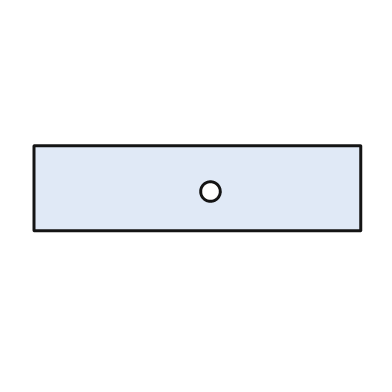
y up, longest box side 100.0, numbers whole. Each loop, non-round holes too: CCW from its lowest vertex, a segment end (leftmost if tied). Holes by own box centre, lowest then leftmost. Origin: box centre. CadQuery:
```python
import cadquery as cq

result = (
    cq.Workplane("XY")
    .moveTo(-50.0, -13.0)
    .lineTo(50.0, -13.0)
    .lineTo(50.0, 13.0)
    .lineTo(-50.0, 13.0)
    .close()
    .moveTo(4.0, -1.0)
    .circle(3.0)
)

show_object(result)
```